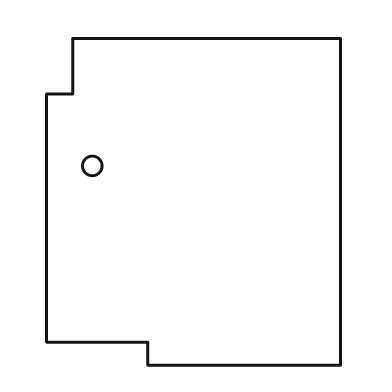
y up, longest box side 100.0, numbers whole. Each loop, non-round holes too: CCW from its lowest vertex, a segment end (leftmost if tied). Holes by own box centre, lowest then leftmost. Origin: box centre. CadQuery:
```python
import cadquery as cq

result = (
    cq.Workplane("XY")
    .moveTo(-14.0, -50.0)
    .lineTo(45.0, -50.0)
    .lineTo(45.0, 50.0)
    .lineTo(-37.0, 50.0)
    .lineTo(-37.0, 33.0)
    .lineTo(-45.0, 33.0)
    .lineTo(-45.0, -43.0)
    .lineTo(-14.0, -43.0)
    .close()
    .moveTo(-31.0, 11.0)
    .circle(3.0)
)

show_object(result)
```